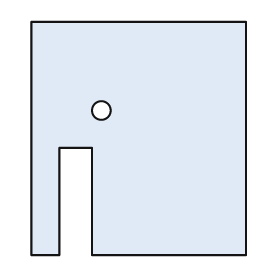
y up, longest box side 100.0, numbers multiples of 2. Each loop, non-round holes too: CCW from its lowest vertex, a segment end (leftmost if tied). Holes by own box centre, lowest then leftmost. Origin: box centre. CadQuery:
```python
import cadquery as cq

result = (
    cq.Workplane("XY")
    .moveTo(-46.0, -50.0)
    .lineTo(-34.0, -50.0)
    .lineTo(-34.0, -4.0)
    .lineTo(-20.0, -4.0)
    .lineTo(-20.0, -50.0)
    .lineTo(46.0, -50.0)
    .lineTo(46.0, 50.0)
    .lineTo(-46.0, 50.0)
    .close()
    .moveTo(-16.0, 12.0)
    .circle(4.0)
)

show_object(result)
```